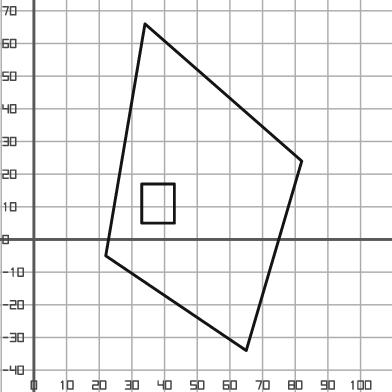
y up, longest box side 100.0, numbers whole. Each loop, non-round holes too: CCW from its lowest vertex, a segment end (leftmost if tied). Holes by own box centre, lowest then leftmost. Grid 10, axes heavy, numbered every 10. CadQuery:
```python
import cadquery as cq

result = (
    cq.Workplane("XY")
    .moveTo(65.0, -34.0)
    .lineTo(82.0, 24.0)
    .lineTo(34.0, 66.0)
    .lineTo(22.0, -5.0)
    .close()
    .moveTo(33.0, 5.0)
    .lineTo(43.0, 5.0)
    .lineTo(43.0, 17.0)
    .lineTo(33.0, 17.0)
    .close()
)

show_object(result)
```